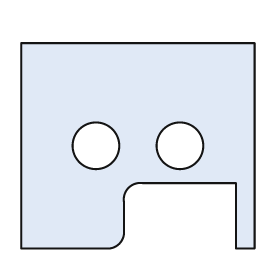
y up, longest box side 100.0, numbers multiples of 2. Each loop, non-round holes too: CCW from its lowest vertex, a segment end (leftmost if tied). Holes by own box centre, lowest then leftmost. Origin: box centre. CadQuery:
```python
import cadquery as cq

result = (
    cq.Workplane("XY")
    .moveTo(-50.0, -44.0)
    .lineTo(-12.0, -44.0)
    .threePointArc((-8.0, -42.0), (-6.0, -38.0))
    .lineTo(-6.0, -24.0)
    .threePointArc((-4.0, -18.0), (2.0, -16.0))
    .lineTo(42.0, -16.0)
    .lineTo(42.0, -44.0)
    .lineTo(50.0, -44.0)
    .lineTo(50.0, 44.0)
    .lineTo(-50.0, 44.0)
    .close()
    .moveTo(-18.0, 0.0)
    .circle(10.0)
    .moveTo(18.0, 0.0)
    .circle(10.0)
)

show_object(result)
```